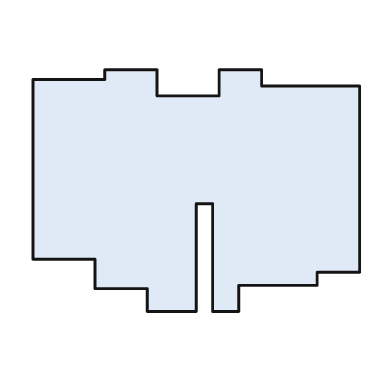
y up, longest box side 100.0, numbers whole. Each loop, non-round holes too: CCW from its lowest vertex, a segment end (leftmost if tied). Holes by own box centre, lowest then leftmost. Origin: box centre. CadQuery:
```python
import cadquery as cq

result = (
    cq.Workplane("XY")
    .moveTo(-15.0, -37.0)
    .lineTo(0.0, -37.0)
    .lineTo(0.0, -4.0)
    .lineTo(5.0, -4.0)
    .lineTo(5.0, -37.0)
    .lineTo(13.0, -37.0)
    .lineTo(13.0, -29.0)
    .lineTo(37.0, -29.0)
    .lineTo(37.0, -25.0)
    .lineTo(50.0, -25.0)
    .lineTo(50.0, 32.0)
    .lineTo(20.0, 32.0)
    .lineTo(20.0, 37.0)
    .lineTo(7.0, 37.0)
    .lineTo(7.0, 29.0)
    .lineTo(-12.0, 29.0)
    .lineTo(-12.0, 37.0)
    .lineTo(-28.0, 37.0)
    .lineTo(-28.0, 34.0)
    .lineTo(-50.0, 34.0)
    .lineTo(-50.0, -21.0)
    .lineTo(-31.0, -21.0)
    .lineTo(-31.0, -30.0)
    .lineTo(-15.0, -30.0)
    .close()
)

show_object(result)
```